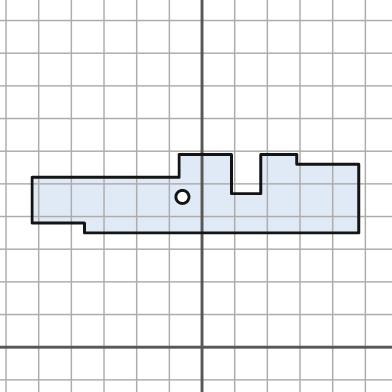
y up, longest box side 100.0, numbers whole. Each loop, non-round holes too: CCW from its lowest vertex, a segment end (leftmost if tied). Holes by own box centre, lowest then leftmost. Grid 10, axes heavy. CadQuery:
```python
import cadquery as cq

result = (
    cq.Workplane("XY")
    .moveTo(-36.0, 35.0)
    .lineTo(48.0, 35.0)
    .lineTo(48.0, 56.0)
    .lineTo(29.0, 56.0)
    .lineTo(29.0, 59.0)
    .lineTo(18.0, 59.0)
    .lineTo(18.0, 47.0)
    .lineTo(9.0, 47.0)
    .lineTo(9.0, 59.0)
    .lineTo(-7.0, 59.0)
    .lineTo(-7.0, 52.0)
    .lineTo(-52.0, 52.0)
    .lineTo(-52.0, 38.0)
    .lineTo(-36.0, 38.0)
    .close()
    .moveTo(-6.0, 46.0)
    .circle(2.0)
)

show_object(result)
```